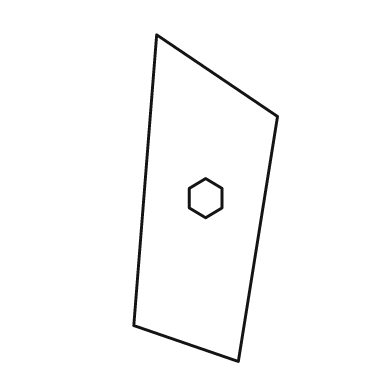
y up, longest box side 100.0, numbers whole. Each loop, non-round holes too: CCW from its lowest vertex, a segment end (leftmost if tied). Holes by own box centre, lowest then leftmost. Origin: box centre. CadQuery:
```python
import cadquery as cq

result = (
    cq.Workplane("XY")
    .moveTo(10.0, -50.0)
    .lineTo(22.0, 25.0)
    .lineTo(-15.0, 50.0)
    .lineTo(-22.0, -39.0)
    .close()
    .moveTo(0.0, -6.0)
    .lineTo(5.0, -3.0)
    .lineTo(5.0, 3.0)
    .lineTo(0.0, 6.0)
    .lineTo(-5.0, 3.0)
    .lineTo(-5.0, -3.0)
    .close()
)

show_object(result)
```